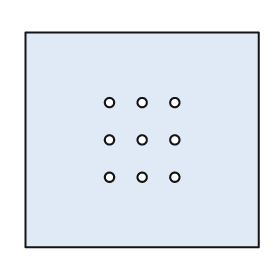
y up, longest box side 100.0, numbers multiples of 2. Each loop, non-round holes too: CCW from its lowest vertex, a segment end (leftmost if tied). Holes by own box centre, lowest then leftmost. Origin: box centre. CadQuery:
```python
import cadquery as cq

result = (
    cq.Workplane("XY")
    .moveTo(-50.0, -46.0)
    .lineTo(50.0, -46.0)
    .lineTo(50.0, 46.0)
    .lineTo(-50.0, 46.0)
    .close()
    .moveTo(-14.0, -16.0)
    .circle(2.0)
    .moveTo(0.0, -16.0)
    .circle(2.0)
    .moveTo(14.0, -16.0)
    .circle(2.0)
    .moveTo(-14.0, 0.0)
    .circle(2.0)
    .moveTo(0.0, 0.0)
    .circle(2.0)
    .moveTo(14.0, 0.0)
    .circle(2.0)
    .moveTo(-14.0, 16.0)
    .circle(2.0)
    .moveTo(0.0, 16.0)
    .circle(2.0)
    .moveTo(14.0, 16.0)
    .circle(2.0)
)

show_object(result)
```